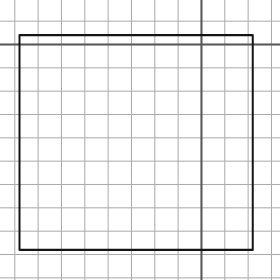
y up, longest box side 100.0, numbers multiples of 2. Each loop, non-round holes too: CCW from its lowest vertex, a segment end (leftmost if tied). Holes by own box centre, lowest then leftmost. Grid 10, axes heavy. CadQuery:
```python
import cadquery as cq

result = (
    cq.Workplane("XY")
    .moveTo(-78.0, -88.0)
    .lineTo(22.0, -88.0)
    .lineTo(22.0, 4.0)
    .lineTo(-78.0, 4.0)
    .close()
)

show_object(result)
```